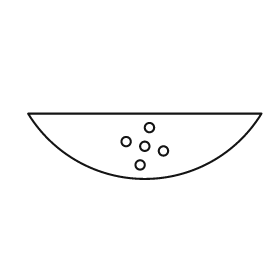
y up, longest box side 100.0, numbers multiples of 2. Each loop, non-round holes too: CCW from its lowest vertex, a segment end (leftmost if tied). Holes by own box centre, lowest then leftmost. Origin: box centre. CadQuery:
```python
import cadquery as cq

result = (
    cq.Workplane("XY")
    .moveTo(-50.0, 14.0)
    .threePointArc((0.0, -14.0), (50.0, 14.0))
    .close()
    .moveTo(-2.0, -8.0)
    .circle(2.0)
    .moveTo(8.0, -2.0)
    .circle(2.0)
    .moveTo(0.0, 0.0)
    .circle(2.0)
    .moveTo(-8.0, 2.0)
    .circle(2.0)
    .moveTo(2.0, 8.0)
    .circle(2.0)
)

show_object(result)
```